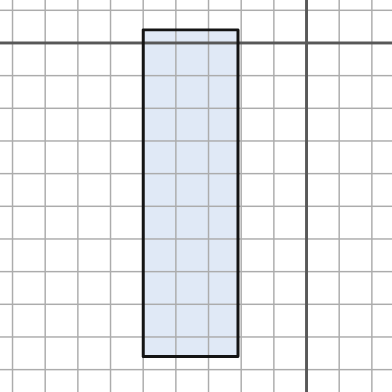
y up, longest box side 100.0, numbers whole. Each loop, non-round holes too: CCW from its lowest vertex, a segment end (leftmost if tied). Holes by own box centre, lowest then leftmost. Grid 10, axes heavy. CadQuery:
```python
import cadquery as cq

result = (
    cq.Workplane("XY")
    .moveTo(-50.0, -96.0)
    .lineTo(-21.0, -96.0)
    .lineTo(-21.0, 4.0)
    .lineTo(-50.0, 4.0)
    .close()
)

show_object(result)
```